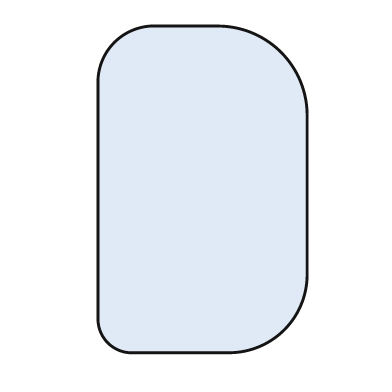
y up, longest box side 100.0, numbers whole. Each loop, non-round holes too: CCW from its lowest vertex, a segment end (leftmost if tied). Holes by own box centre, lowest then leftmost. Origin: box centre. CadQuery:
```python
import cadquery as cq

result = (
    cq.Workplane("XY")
    .moveTo(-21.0, -50.0)
    .lineTo(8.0, -50.0)
    .threePointArc((25.0, -43.0), (32.0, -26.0))
    .lineTo(32.0, 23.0)
    .threePointArc((24.0, 42.0), (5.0, 50.0))
    .lineTo(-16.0, 50.0)
    .threePointArc((-27.0, 45.0), (-32.0, 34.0))
    .lineTo(-32.0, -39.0)
    .threePointArc((-29.0, -47.0), (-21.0, -50.0))
    .close()
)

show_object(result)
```